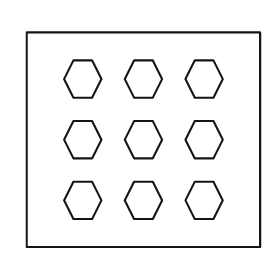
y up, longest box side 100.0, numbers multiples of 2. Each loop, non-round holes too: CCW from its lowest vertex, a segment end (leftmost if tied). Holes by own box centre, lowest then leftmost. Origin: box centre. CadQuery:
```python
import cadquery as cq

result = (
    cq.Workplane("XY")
    .moveTo(-50.0, -46.0)
    .lineTo(50.0, -46.0)
    .lineTo(50.0, 46.0)
    .lineTo(-50.0, 46.0)
    .close()
    .moveTo(-30.0, -34.0)
    .lineTo(-22.0, -34.0)
    .lineTo(-18.0, -26.0)
    .lineTo(-22.0, -18.0)
    .lineTo(-30.0, -18.0)
    .lineTo(-34.0, -26.0)
    .close()
    .moveTo(-4.0, -34.0)
    .lineTo(4.0, -34.0)
    .lineTo(8.0, -26.0)
    .lineTo(4.0, -18.0)
    .lineTo(-4.0, -18.0)
    .lineTo(-8.0, -26.0)
    .close()
    .moveTo(22.0, -34.0)
    .lineTo(30.0, -34.0)
    .lineTo(34.0, -26.0)
    .lineTo(30.0, -18.0)
    .lineTo(22.0, -18.0)
    .lineTo(18.0, -26.0)
    .close()
    .moveTo(-30.0, -8.0)
    .lineTo(-22.0, -8.0)
    .lineTo(-18.0, 0.0)
    .lineTo(-22.0, 8.0)
    .lineTo(-30.0, 8.0)
    .lineTo(-34.0, 0.0)
    .close()
    .moveTo(-4.0, -8.0)
    .lineTo(4.0, -8.0)
    .lineTo(8.0, 0.0)
    .lineTo(4.0, 8.0)
    .lineTo(-4.0, 8.0)
    .lineTo(-8.0, 0.0)
    .close()
    .moveTo(22.0, -8.0)
    .lineTo(30.0, -8.0)
    .lineTo(34.0, 0.0)
    .lineTo(30.0, 8.0)
    .lineTo(22.0, 8.0)
    .lineTo(18.0, 0.0)
    .close()
    .moveTo(-30.0, 18.0)
    .lineTo(-22.0, 18.0)
    .lineTo(-18.0, 26.0)
    .lineTo(-22.0, 34.0)
    .lineTo(-30.0, 34.0)
    .lineTo(-34.0, 26.0)
    .close()
    .moveTo(-4.0, 18.0)
    .lineTo(4.0, 18.0)
    .lineTo(8.0, 26.0)
    .lineTo(4.0, 34.0)
    .lineTo(-4.0, 34.0)
    .lineTo(-8.0, 26.0)
    .close()
    .moveTo(22.0, 18.0)
    .lineTo(30.0, 18.0)
    .lineTo(34.0, 26.0)
    .lineTo(30.0, 34.0)
    .lineTo(22.0, 34.0)
    .lineTo(18.0, 26.0)
    .close()
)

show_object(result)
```